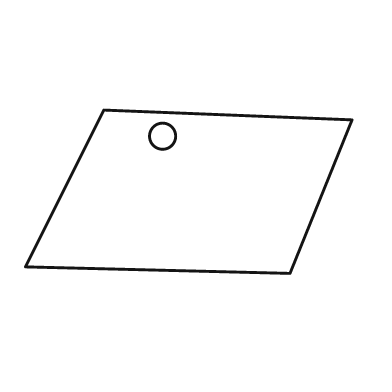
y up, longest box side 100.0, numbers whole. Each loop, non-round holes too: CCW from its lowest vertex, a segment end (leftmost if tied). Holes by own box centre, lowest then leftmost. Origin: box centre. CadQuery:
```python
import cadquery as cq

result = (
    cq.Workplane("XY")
    .moveTo(31.0, -25.0)
    .lineTo(50.0, 22.0)
    .lineTo(-26.0, 25.0)
    .lineTo(-50.0, -23.0)
    .close()
    .moveTo(-8.0, 17.0)
    .circle(4.0)
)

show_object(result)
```